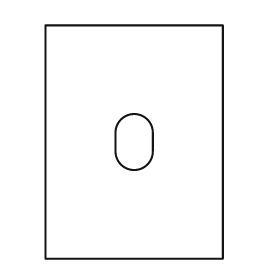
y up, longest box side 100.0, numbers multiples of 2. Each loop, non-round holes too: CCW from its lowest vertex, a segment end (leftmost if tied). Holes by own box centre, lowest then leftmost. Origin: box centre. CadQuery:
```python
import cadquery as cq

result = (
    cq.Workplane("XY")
    .moveTo(-38.0, -50.0)
    .lineTo(38.0, -50.0)
    .lineTo(38.0, 50.0)
    .lineTo(-38.0, 50.0)
    .close()
    .moveTo(-8.0, -4.0)
    .threePointArc((0.0, -12.0), (8.0, -4.0))
    .lineTo(8.0, 4.0)
    .threePointArc((0.0, 12.0), (-8.0, 4.0))
    .close()
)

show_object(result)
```